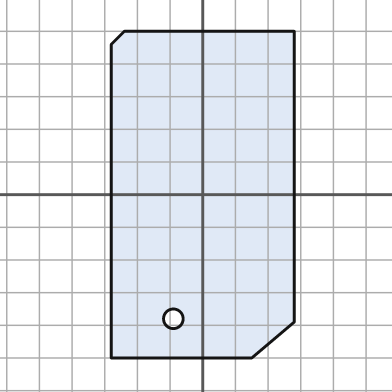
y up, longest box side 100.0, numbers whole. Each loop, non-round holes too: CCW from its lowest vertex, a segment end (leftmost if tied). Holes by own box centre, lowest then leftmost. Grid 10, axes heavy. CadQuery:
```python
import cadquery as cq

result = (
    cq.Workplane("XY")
    .moveTo(-28.0, -50.0)
    .lineTo(15.0, -50.0)
    .lineTo(28.0, -39.0)
    .lineTo(28.0, 50.0)
    .lineTo(-24.0, 50.0)
    .lineTo(-28.0, 46.0)
    .close()
    .moveTo(-9.0, -38.0)
    .circle(3.0)
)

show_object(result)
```